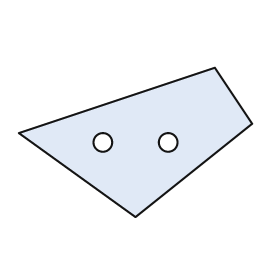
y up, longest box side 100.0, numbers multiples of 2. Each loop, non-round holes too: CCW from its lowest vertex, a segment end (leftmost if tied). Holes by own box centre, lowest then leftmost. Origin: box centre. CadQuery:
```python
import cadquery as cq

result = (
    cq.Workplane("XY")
    .moveTo(0.0, -32.0)
    .lineTo(50.0, 8.0)
    .lineTo(34.0, 32.0)
    .lineTo(-50.0, 4.0)
    .close()
    .moveTo(-14.0, 0.0)
    .circle(4.0)
    .moveTo(14.0, 0.0)
    .circle(4.0)
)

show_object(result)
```